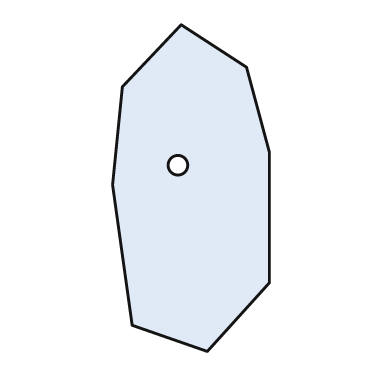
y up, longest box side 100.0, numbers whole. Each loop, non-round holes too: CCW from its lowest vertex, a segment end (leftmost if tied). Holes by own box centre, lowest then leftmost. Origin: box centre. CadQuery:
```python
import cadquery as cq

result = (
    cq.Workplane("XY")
    .moveTo(5.0, -50.0)
    .lineTo(24.0, -29.0)
    .lineTo(24.0, 11.0)
    .lineTo(17.0, 37.0)
    .lineTo(-3.0, 50.0)
    .lineTo(-21.0, 31.0)
    .lineTo(-24.0, 1.0)
    .lineTo(-18.0, -42.0)
    .close()
    .moveTo(-4.0, 7.0)
    .circle(3.0)
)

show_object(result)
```